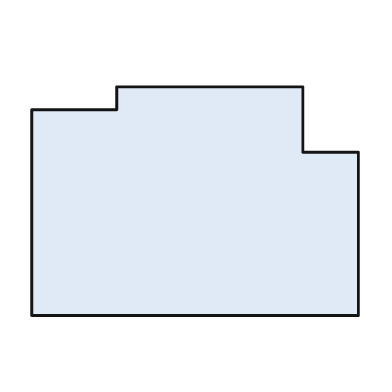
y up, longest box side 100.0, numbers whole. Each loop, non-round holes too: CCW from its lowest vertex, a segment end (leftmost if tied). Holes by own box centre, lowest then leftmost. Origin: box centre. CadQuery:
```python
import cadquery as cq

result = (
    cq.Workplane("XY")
    .moveTo(-50.0, -35.0)
    .lineTo(50.0, -35.0)
    .lineTo(50.0, 15.0)
    .lineTo(33.0, 15.0)
    .lineTo(33.0, 35.0)
    .lineTo(-24.0, 35.0)
    .lineTo(-24.0, 28.0)
    .lineTo(-50.0, 28.0)
    .close()
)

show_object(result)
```